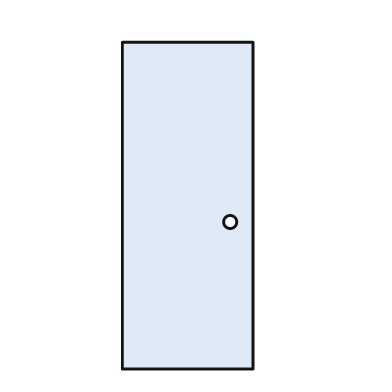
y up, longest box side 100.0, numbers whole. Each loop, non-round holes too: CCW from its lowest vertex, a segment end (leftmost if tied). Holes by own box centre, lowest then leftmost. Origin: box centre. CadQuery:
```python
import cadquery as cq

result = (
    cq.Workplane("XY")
    .moveTo(-20.0, -50.0)
    .lineTo(20.0, -50.0)
    .lineTo(20.0, 50.0)
    .lineTo(-20.0, 50.0)
    .close()
    .moveTo(13.0, -5.0)
    .circle(2.0)
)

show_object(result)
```